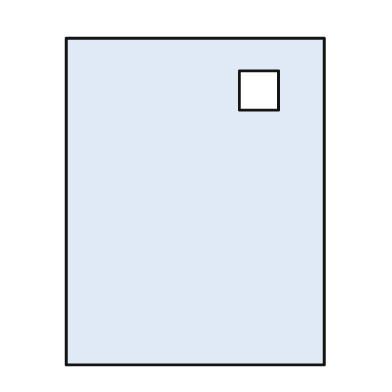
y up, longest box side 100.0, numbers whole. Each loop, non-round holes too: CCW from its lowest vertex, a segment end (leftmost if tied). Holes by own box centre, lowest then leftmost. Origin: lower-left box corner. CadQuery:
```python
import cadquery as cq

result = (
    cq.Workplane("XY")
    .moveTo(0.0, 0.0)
    .lineTo(79.0, 0.0)
    .lineTo(79.0, 100.0)
    .lineTo(0.0, 100.0)
    .close()
    .moveTo(53.0, 78.0)
    .lineTo(65.0, 78.0)
    .lineTo(65.0, 90.0)
    .lineTo(53.0, 90.0)
    .close()
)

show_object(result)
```